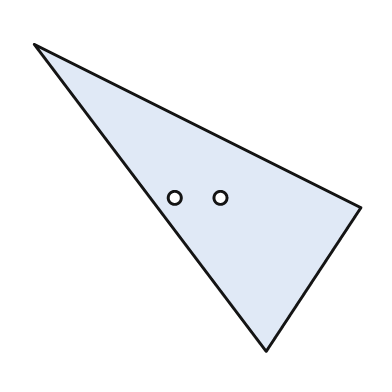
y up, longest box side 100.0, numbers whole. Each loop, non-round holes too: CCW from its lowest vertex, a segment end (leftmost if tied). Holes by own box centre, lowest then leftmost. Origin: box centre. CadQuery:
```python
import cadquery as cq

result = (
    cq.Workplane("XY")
    .moveTo(21.0, -47.0)
    .lineTo(50.0, -3.0)
    .lineTo(-50.0, 47.0)
    .close()
    .moveTo(-7.0, 0.0)
    .circle(2.0)
    .moveTo(7.0, 0.0)
    .circle(2.0)
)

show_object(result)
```